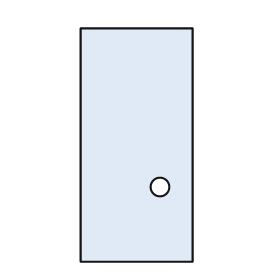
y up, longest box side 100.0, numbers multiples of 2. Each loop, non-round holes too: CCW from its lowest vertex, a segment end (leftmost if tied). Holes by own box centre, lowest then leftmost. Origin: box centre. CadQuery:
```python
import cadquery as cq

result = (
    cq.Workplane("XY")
    .moveTo(-24.0, -50.0)
    .lineTo(24.0, -50.0)
    .lineTo(24.0, 50.0)
    .lineTo(-24.0, 50.0)
    .close()
    .moveTo(10.0, -18.0)
    .circle(4.0)
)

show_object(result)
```